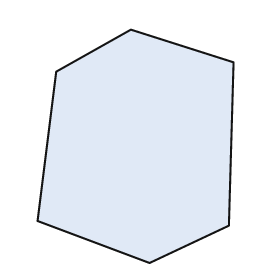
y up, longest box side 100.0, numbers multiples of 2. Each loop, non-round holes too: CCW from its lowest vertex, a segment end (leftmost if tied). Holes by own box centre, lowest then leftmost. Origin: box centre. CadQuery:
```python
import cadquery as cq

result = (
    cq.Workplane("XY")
    .moveTo(6.0, -50.0)
    .lineTo(40.0, -34.0)
    .lineTo(42.0, 36.0)
    .lineTo(-2.0, 50.0)
    .lineTo(-34.0, 32.0)
    .lineTo(-42.0, -32.0)
    .close()
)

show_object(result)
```